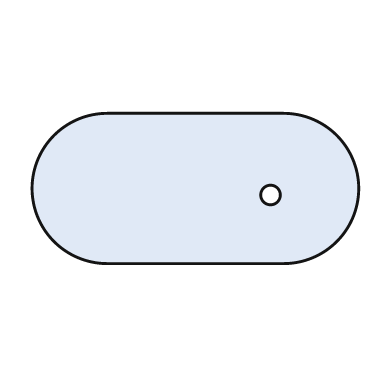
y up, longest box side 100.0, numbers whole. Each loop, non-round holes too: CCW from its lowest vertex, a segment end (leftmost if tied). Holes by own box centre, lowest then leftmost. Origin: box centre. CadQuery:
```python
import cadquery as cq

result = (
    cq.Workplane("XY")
    .moveTo(-27.0, -23.0)
    .lineTo(27.0, -23.0)
    .threePointArc((50.0, 0.0), (27.0, 23.0))
    .lineTo(-27.0, 23.0)
    .threePointArc((-50.0, 0.0), (-27.0, -23.0))
    .close()
    .moveTo(23.0, -2.0)
    .circle(3.0)
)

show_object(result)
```